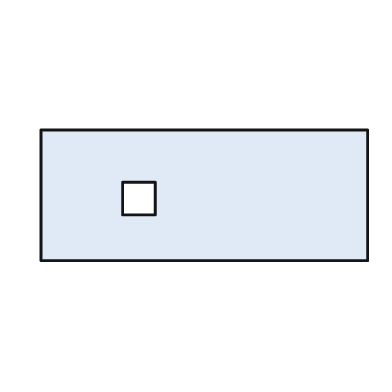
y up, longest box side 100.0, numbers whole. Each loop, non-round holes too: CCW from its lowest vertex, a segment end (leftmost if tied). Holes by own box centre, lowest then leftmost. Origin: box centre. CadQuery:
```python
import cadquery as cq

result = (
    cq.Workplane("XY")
    .moveTo(-50.0, -20.0)
    .lineTo(50.0, -20.0)
    .lineTo(50.0, 20.0)
    .lineTo(-50.0, 20.0)
    .close()
    .moveTo(-25.0, -6.0)
    .lineTo(-15.0, -6.0)
    .lineTo(-15.0, 4.0)
    .lineTo(-25.0, 4.0)
    .close()
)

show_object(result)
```